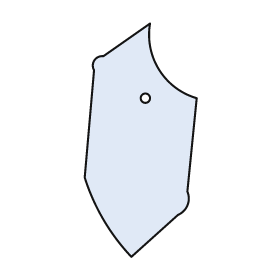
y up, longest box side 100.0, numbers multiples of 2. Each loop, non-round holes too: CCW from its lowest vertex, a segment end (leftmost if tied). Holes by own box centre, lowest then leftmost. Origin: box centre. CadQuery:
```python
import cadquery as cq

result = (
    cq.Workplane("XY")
    .moveTo(-4.0, -50.0)
    .lineTo(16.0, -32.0)
    .threePointArc((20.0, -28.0), (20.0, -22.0))
    .lineTo(24.0, 18.0)
    .threePointArc((8.0, 30.0), (4.0, 50.0))
    .lineTo(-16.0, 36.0)
    .threePointArc((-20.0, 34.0), (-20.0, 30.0))
    .lineTo(-24.0, -16.0)
    .threePointArc((-16.0, -34.0), (-4.0, -50.0))
    .close()
    .moveTo(2.0, 18.0)
    .circle(2.0)
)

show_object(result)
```